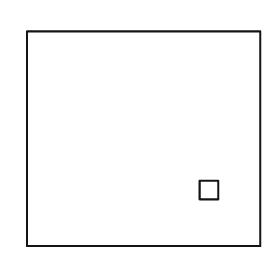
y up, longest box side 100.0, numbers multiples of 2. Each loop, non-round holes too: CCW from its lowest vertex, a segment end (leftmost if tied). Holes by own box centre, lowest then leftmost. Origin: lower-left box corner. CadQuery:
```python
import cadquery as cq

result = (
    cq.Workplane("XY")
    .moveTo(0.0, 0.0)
    .lineTo(100.0, 0.0)
    .lineTo(100.0, 92.0)
    .lineTo(0.0, 92.0)
    .close()
    .moveTo(74.0, 20.0)
    .lineTo(82.0, 20.0)
    .lineTo(82.0, 28.0)
    .lineTo(74.0, 28.0)
    .close()
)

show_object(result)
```